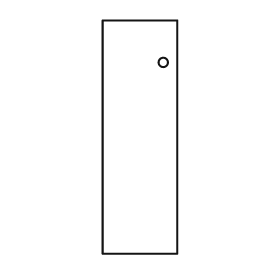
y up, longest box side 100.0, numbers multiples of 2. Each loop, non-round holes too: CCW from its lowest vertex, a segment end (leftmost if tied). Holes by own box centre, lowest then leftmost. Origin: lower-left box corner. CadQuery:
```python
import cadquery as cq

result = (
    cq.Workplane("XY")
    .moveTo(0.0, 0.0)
    .lineTo(32.0, 0.0)
    .lineTo(32.0, 100.0)
    .lineTo(0.0, 100.0)
    .close()
    .moveTo(26.0, 82.0)
    .circle(2.0)
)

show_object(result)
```